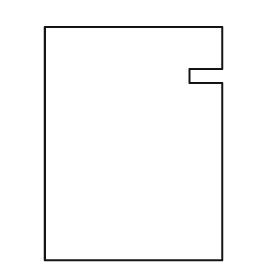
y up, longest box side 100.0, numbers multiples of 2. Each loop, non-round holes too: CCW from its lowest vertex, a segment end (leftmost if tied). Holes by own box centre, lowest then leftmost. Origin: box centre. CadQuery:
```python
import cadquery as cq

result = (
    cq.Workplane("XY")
    .moveTo(-38.0, -50.0)
    .lineTo(38.0, -50.0)
    .lineTo(38.0, 26.0)
    .lineTo(24.0, 26.0)
    .lineTo(24.0, 32.0)
    .lineTo(38.0, 32.0)
    .lineTo(38.0, 50.0)
    .lineTo(-38.0, 50.0)
    .close()
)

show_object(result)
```